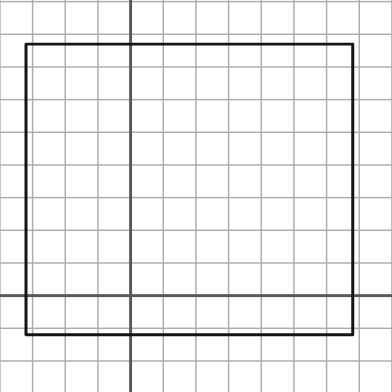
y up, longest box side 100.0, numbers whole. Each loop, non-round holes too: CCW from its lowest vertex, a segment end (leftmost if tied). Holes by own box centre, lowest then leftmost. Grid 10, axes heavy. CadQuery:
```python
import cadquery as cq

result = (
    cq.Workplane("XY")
    .moveTo(-32.0, -12.0)
    .lineTo(68.0, -12.0)
    .lineTo(68.0, 77.0)
    .lineTo(-32.0, 77.0)
    .close()
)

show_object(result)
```